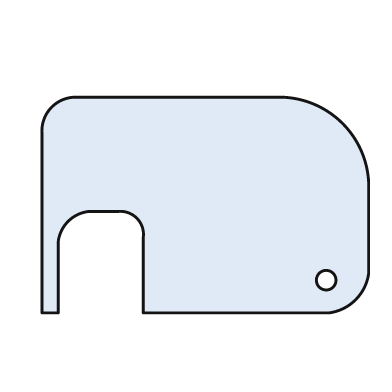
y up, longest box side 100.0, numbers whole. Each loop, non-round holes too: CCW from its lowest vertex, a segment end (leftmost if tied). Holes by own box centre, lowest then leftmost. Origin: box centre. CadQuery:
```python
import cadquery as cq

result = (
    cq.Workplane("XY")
    .moveTo(-50.0, -33.0)
    .lineTo(-45.0, -33.0)
    .lineTo(-45.0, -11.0)
    .threePointArc((-42.0, -5.0), (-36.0, -2.0))
    .lineTo(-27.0, -2.0)
    .threePointArc((-21.0, -4.0), (-19.0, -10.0))
    .lineTo(-19.0, -33.0)
    .lineTo(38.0, -33.0)
    .threePointArc((46.0, -29.0), (50.0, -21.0))
    .lineTo(50.0, 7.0)
    .threePointArc((42.0, 25.0), (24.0, 33.0))
    .lineTo(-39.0, 33.0)
    .threePointArc((-47.0, 30.0), (-50.0, 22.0))
    .close()
    .moveTo(37.0, -23.0)
    .circle(3.0)
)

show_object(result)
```